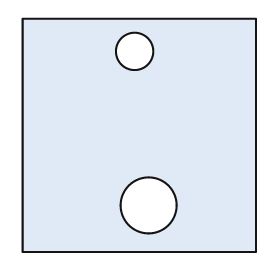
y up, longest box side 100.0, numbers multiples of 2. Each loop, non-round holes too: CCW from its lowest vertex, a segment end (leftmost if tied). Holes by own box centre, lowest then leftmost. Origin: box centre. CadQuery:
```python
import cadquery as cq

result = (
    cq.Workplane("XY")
    .moveTo(-50.0, -50.0)
    .lineTo(50.0, -50.0)
    .lineTo(50.0, 50.0)
    .lineTo(-50.0, 50.0)
    .close()
    .moveTo(4.0, -30.0)
    .circle(12.0)
    .moveTo(-2.0, 36.0)
    .circle(8.0)
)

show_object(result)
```